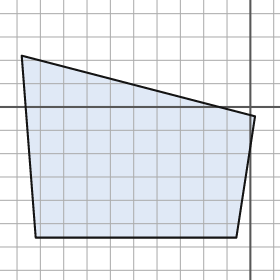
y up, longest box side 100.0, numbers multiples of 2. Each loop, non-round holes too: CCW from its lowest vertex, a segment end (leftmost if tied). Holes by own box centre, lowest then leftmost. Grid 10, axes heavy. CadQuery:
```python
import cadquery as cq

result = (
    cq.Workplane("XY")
    .moveTo(-92.0, -56.0)
    .lineTo(-6.0, -56.0)
    .lineTo(2.0, -4.0)
    .lineTo(-98.0, 22.0)
    .close()
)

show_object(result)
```